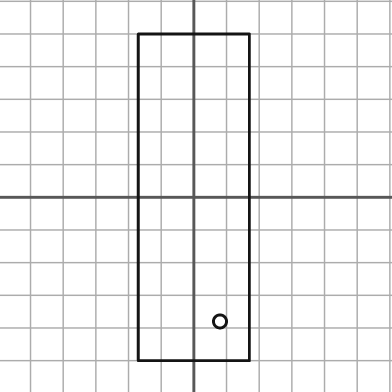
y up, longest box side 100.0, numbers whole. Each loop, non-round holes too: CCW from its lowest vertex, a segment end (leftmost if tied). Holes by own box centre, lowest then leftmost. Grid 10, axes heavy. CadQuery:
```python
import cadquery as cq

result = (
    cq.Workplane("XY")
    .moveTo(-17.0, -50.0)
    .lineTo(17.0, -50.0)
    .lineTo(17.0, 50.0)
    .lineTo(-17.0, 50.0)
    .close()
    .moveTo(8.0, -38.0)
    .circle(2.0)
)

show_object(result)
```